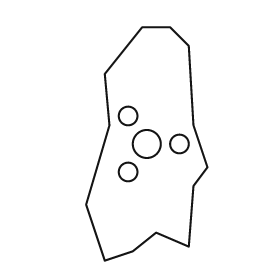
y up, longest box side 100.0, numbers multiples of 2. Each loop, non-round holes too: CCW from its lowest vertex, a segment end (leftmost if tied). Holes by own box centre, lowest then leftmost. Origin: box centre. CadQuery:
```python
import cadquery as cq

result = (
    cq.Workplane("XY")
    .moveTo(-18.0, -50.0)
    .lineTo(-6.0, -46.0)
    .lineTo(4.0, -38.0)
    .lineTo(18.0, -44.0)
    .lineTo(20.0, -18.0)
    .lineTo(26.0, -10.0)
    .lineTo(20.0, 8.0)
    .lineTo(18.0, 42.0)
    .lineTo(10.0, 50.0)
    .lineTo(-2.0, 50.0)
    .lineTo(-18.0, 30.0)
    .lineTo(-16.0, 8.0)
    .lineTo(-26.0, -26.0)
    .close()
    .moveTo(-8.0, -12.0)
    .circle(4.0)
    .moveTo(0.0, 0.0)
    .circle(6.0)
    .moveTo(14.0, 0.0)
    .circle(4.0)
    .moveTo(-8.0, 12.0)
    .circle(4.0)
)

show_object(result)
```